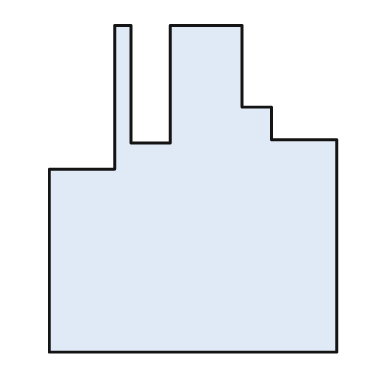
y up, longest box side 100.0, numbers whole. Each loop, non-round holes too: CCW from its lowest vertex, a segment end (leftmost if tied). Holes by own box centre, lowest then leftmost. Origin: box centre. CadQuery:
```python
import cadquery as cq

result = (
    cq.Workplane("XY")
    .moveTo(-44.0, -50.0)
    .lineTo(44.0, -50.0)
    .lineTo(44.0, 15.0)
    .lineTo(24.0, 15.0)
    .lineTo(24.0, 25.0)
    .lineTo(15.0, 25.0)
    .lineTo(15.0, 50.0)
    .lineTo(-7.0, 50.0)
    .lineTo(-7.0, 14.0)
    .lineTo(-19.0, 14.0)
    .lineTo(-19.0, 50.0)
    .lineTo(-24.0, 50.0)
    .lineTo(-24.0, 6.0)
    .lineTo(-44.0, 6.0)
    .close()
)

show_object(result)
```